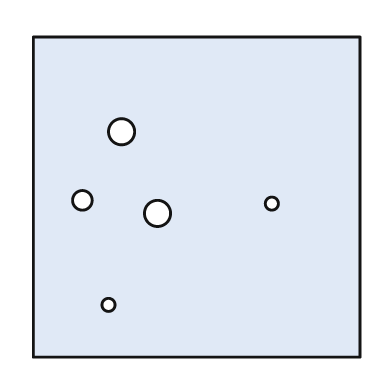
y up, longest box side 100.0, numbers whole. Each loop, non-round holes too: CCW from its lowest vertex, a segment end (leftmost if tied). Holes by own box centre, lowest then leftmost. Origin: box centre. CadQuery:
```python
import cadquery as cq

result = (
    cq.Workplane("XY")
    .moveTo(-50.0, -49.0)
    .lineTo(50.0, -49.0)
    .lineTo(50.0, 49.0)
    .lineTo(-50.0, 49.0)
    .close()
    .moveTo(-27.0, -33.0)
    .circle(2.0)
    .moveTo(-12.0, -5.0)
    .circle(4.0)
    .moveTo(23.0, -2.0)
    .circle(2.0)
    .moveTo(-35.0, -1.0)
    .circle(3.0)
    .moveTo(-23.0, 20.0)
    .circle(4.0)
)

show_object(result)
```